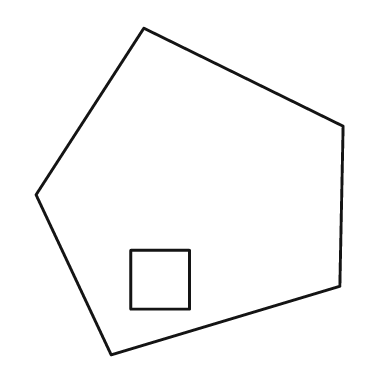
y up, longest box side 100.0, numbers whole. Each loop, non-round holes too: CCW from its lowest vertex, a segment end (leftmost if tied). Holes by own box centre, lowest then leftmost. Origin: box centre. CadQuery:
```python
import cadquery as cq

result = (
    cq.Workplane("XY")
    .moveTo(-24.0, -50.0)
    .lineTo(46.0, -29.0)
    .lineTo(47.0, 20.0)
    .lineTo(-14.0, 50.0)
    .lineTo(-47.0, -1.0)
    .close()
    .moveTo(-18.0, -36.0)
    .lineTo(0.0, -36.0)
    .lineTo(0.0, -18.0)
    .lineTo(-18.0, -18.0)
    .close()
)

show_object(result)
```